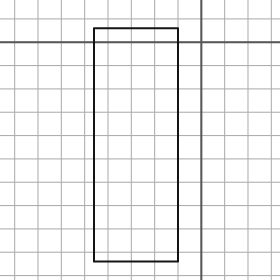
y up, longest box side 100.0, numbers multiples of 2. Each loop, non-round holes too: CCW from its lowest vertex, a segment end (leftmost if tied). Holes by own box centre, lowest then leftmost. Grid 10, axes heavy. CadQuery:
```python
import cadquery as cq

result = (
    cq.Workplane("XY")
    .moveTo(-46.0, -94.0)
    .lineTo(-10.0, -94.0)
    .lineTo(-10.0, 6.0)
    .lineTo(-46.0, 6.0)
    .close()
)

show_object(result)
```